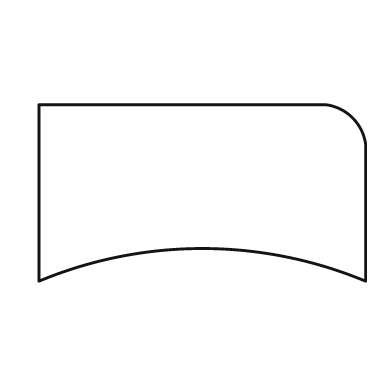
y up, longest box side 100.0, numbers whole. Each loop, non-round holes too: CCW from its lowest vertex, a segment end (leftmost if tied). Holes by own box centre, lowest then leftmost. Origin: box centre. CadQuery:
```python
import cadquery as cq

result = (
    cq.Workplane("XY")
    .moveTo(-50.0, -27.0)
    .threePointArc((0.0, -17.0), (50.0, -27.0))
    .lineTo(50.0, 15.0)
    .threePointArc((46.0, 23.0), (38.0, 27.0))
    .lineTo(-50.0, 27.0)
    .close()
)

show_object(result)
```